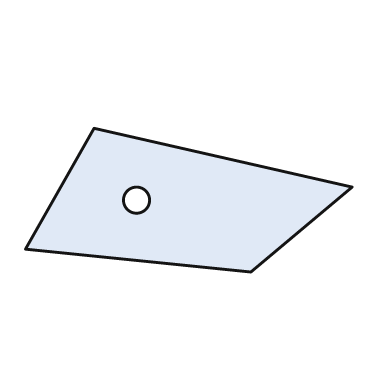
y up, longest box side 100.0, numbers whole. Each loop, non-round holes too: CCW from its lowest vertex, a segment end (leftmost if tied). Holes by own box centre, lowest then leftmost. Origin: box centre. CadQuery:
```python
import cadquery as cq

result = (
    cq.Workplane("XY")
    .moveTo(19.0, -22.0)
    .lineTo(50.0, 4.0)
    .lineTo(-29.0, 22.0)
    .lineTo(-50.0, -15.0)
    .close()
    .moveTo(-16.0, 0.0)
    .circle(4.0)
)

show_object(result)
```